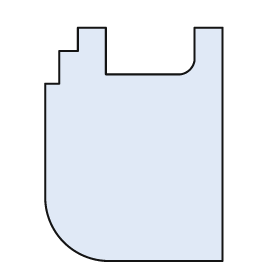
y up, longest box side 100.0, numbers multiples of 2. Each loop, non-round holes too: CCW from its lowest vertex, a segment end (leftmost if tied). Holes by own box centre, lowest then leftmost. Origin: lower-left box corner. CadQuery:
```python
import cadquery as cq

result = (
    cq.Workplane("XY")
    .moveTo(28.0, 0.0)
    .lineTo(76.0, 0.0)
    .lineTo(76.0, 100.0)
    .lineTo(64.0, 100.0)
    .lineTo(64.0, 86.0)
    .threePointArc((62.0, 82.0), (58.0, 80.0))
    .lineTo(26.0, 80.0)
    .lineTo(26.0, 100.0)
    .lineTo(14.0, 100.0)
    .lineTo(14.0, 90.0)
    .lineTo(6.0, 90.0)
    .lineTo(6.0, 76.0)
    .lineTo(0.0, 76.0)
    .lineTo(0.0, 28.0)
    .threePointArc((8.0, 8.0), (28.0, 0.0))
    .close()
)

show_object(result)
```